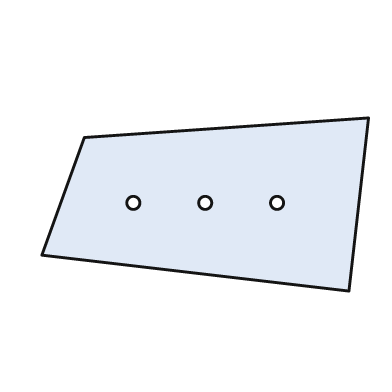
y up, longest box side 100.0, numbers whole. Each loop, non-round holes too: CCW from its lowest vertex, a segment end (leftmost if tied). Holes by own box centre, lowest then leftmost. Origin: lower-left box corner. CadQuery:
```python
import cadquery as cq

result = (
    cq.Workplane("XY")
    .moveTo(94.0, 0.0)
    .lineTo(100.0, 53.0)
    .lineTo(13.0, 47.0)
    .lineTo(0.0, 11.0)
    .close()
    .moveTo(28.0, 27.0)
    .circle(2.0)
    .moveTo(50.0, 27.0)
    .circle(2.0)
    .moveTo(72.0, 27.0)
    .circle(2.0)
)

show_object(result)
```